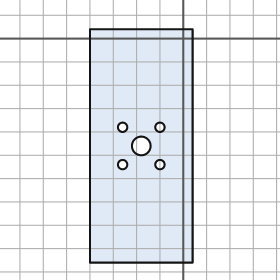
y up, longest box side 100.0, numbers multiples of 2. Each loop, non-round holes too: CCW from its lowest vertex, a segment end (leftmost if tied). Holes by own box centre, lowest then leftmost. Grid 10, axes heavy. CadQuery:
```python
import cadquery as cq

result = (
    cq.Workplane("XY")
    .moveTo(-40.0, -96.0)
    .lineTo(4.0, -96.0)
    .lineTo(4.0, 4.0)
    .lineTo(-40.0, 4.0)
    .close()
    .moveTo(-26.0, -54.0)
    .circle(2.0)
    .moveTo(-10.0, -54.0)
    .circle(2.0)
    .moveTo(-18.0, -46.0)
    .circle(4.0)
    .moveTo(-26.0, -38.0)
    .circle(2.0)
    .moveTo(-10.0, -38.0)
    .circle(2.0)
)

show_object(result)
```